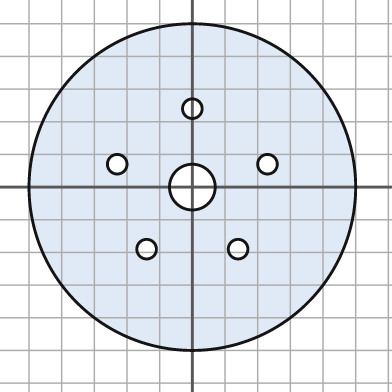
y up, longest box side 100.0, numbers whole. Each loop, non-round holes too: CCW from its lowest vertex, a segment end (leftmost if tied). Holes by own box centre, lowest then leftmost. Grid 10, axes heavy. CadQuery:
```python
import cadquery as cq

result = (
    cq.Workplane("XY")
    .moveTo(0.0, 0.0)
    .circle(50.0)
    .moveTo(-14.0, -19.0)
    .circle(3.0)
    .moveTo(14.0, -19.0)
    .circle(3.0)
    .moveTo(0.0, 0.0)
    .circle(7.0)
    .moveTo(-23.0, 7.0)
    .circle(3.0)
    .moveTo(23.0, 7.0)
    .circle(3.0)
    .moveTo(0.0, 24.0)
    .circle(3.0)
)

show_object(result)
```